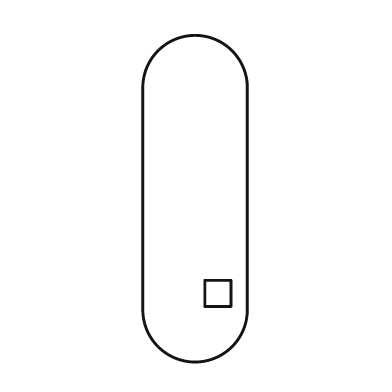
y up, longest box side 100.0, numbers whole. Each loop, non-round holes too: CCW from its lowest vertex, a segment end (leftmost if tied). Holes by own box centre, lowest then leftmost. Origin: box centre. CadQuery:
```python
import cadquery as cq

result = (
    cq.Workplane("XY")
    .moveTo(-16.0, -34.0)
    .threePointArc((0.0, -50.0), (16.0, -34.0))
    .lineTo(16.0, 34.0)
    .threePointArc((0.0, 50.0), (-16.0, 34.0))
    .close()
    .moveTo(3.0, -33.0)
    .lineTo(11.0, -33.0)
    .lineTo(11.0, -25.0)
    .lineTo(3.0, -25.0)
    .close()
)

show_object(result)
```